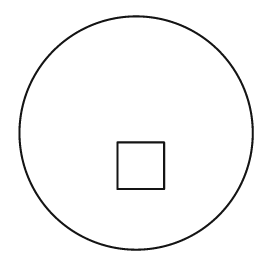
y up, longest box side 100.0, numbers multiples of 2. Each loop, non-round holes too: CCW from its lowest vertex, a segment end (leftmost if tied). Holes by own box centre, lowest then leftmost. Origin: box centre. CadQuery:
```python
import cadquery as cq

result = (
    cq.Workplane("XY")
    .moveTo(0.0, 0.0)
    .circle(50.0)
    .moveTo(-8.0, -24.0)
    .lineTo(12.0, -24.0)
    .lineTo(12.0, -4.0)
    .lineTo(-8.0, -4.0)
    .close()
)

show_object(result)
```